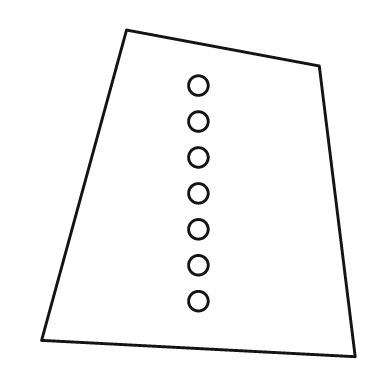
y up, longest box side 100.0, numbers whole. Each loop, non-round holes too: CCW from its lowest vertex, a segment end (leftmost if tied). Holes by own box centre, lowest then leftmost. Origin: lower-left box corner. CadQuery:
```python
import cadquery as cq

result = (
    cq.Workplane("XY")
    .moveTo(96.0, 0.0)
    .lineTo(85.0, 89.0)
    .lineTo(26.0, 100.0)
    .lineTo(0.0, 5.0)
    .close()
    .moveTo(48.0, 17.0)
    .circle(3.0)
    .moveTo(48.0, 28.0)
    .circle(3.0)
    .moveTo(48.0, 39.0)
    .circle(3.0)
    .moveTo(48.0, 50.0)
    .circle(3.0)
    .moveTo(48.0, 61.0)
    .circle(3.0)
    .moveTo(48.0, 72.0)
    .circle(3.0)
    .moveTo(48.0, 83.0)
    .circle(3.0)
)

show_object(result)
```